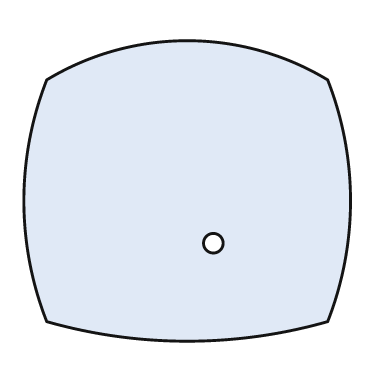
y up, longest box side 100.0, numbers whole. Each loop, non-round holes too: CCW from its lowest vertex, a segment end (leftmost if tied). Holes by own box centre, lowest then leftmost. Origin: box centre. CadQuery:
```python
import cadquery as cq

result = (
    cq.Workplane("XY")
    .moveTo(-43.0, -40.0)
    .threePointArc((0.0, -46.0), (43.0, -40.0))
    .threePointArc((50.0, -3.0), (43.0, 34.0))
    .threePointArc((0.0, 46.0), (-43.0, 34.0))
    .threePointArc((-50.0, -3.0), (-43.0, -40.0))
    .close()
    .moveTo(8.0, -16.0)
    .circle(3.0)
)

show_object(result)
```